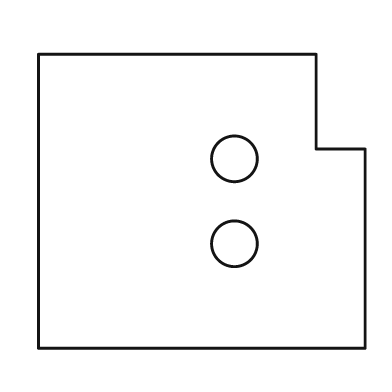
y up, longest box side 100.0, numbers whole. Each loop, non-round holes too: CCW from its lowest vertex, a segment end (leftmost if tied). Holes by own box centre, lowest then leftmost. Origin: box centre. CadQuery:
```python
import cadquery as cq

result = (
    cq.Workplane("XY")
    .moveTo(-50.0, -45.0)
    .lineTo(50.0, -45.0)
    .lineTo(50.0, 16.0)
    .lineTo(35.0, 16.0)
    .lineTo(35.0, 45.0)
    .lineTo(-50.0, 45.0)
    .close()
    .moveTo(10.0, -13.0)
    .circle(7.0)
    .moveTo(10.0, 13.0)
    .circle(7.0)
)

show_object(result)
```